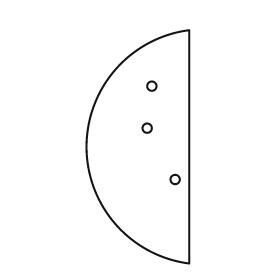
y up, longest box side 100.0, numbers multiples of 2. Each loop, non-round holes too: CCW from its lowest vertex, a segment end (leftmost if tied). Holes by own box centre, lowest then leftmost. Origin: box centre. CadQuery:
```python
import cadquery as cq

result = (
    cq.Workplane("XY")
    .moveTo(22.0, -50.0)
    .lineTo(22.0, 50.0)
    .threePointArc((-22.0, 0.0), (22.0, -50.0))
    .close()
    .moveTo(16.0, -14.0)
    .circle(2.0)
    .moveTo(4.0, 8.0)
    .circle(2.0)
    .moveTo(6.0, 26.0)
    .circle(2.0)
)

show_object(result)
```